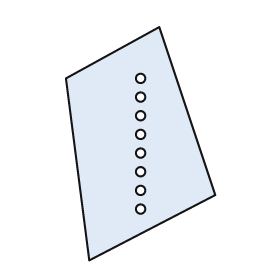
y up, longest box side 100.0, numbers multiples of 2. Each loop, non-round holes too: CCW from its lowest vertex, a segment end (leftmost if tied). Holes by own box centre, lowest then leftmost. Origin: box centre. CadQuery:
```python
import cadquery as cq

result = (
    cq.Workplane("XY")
    .moveTo(-22.0, -50.0)
    .lineTo(32.0, -22.0)
    .lineTo(8.0, 50.0)
    .lineTo(-32.0, 28.0)
    .close()
    .moveTo(0.0, -28.0)
    .circle(2.0)
    .moveTo(0.0, -20.0)
    .circle(2.0)
    .moveTo(0.0, -12.0)
    .circle(2.0)
    .moveTo(0.0, -4.0)
    .circle(2.0)
    .moveTo(0.0, 4.0)
    .circle(2.0)
    .moveTo(0.0, 12.0)
    .circle(2.0)
    .moveTo(0.0, 20.0)
    .circle(2.0)
    .moveTo(0.0, 28.0)
    .circle(2.0)
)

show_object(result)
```